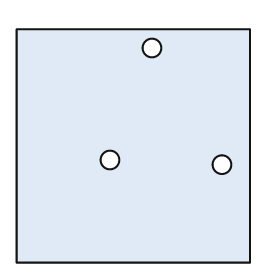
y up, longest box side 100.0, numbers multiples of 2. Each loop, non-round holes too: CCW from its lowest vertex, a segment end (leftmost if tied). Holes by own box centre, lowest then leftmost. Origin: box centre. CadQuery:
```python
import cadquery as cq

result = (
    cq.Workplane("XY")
    .moveTo(-50.0, -50.0)
    .lineTo(50.0, -50.0)
    .lineTo(50.0, 50.0)
    .lineTo(-50.0, 50.0)
    .close()
    .moveTo(38.0, -8.0)
    .circle(4.0)
    .moveTo(-10.0, -6.0)
    .circle(4.0)
    .moveTo(8.0, 42.0)
    .circle(4.0)
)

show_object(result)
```